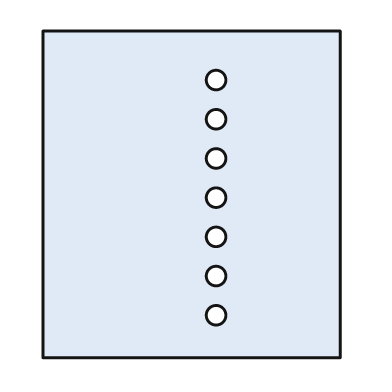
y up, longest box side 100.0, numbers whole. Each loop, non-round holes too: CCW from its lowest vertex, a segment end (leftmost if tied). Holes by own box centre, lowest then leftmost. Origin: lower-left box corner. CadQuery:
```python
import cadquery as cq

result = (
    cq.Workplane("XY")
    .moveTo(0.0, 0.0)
    .lineTo(91.0, 0.0)
    .lineTo(91.0, 100.0)
    .lineTo(0.0, 100.0)
    .close()
    .moveTo(53.0, 13.0)
    .circle(3.0)
    .moveTo(53.0, 25.0)
    .circle(3.0)
    .moveTo(53.0, 37.0)
    .circle(3.0)
    .moveTo(53.0, 49.0)
    .circle(3.0)
    .moveTo(53.0, 61.0)
    .circle(3.0)
    .moveTo(53.0, 73.0)
    .circle(3.0)
    .moveTo(53.0, 85.0)
    .circle(3.0)
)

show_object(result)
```